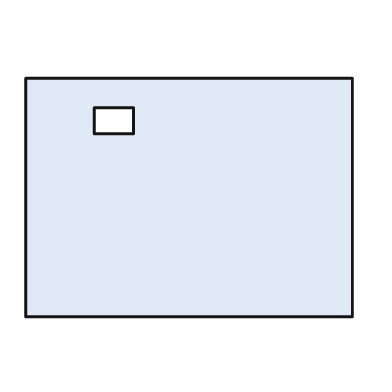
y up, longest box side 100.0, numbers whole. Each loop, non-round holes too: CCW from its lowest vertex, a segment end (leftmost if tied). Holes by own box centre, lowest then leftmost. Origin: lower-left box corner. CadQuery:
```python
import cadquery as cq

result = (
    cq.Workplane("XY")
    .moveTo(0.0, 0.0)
    .lineTo(100.0, 0.0)
    .lineTo(100.0, 73.0)
    .lineTo(0.0, 73.0)
    .close()
    .moveTo(21.0, 56.0)
    .lineTo(33.0, 56.0)
    .lineTo(33.0, 64.0)
    .lineTo(21.0, 64.0)
    .close()
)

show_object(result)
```